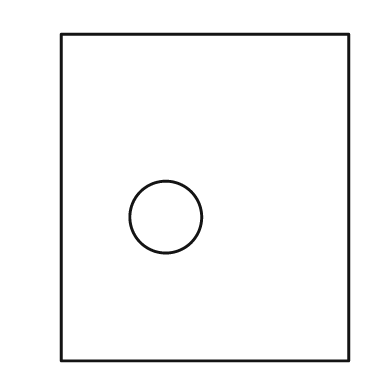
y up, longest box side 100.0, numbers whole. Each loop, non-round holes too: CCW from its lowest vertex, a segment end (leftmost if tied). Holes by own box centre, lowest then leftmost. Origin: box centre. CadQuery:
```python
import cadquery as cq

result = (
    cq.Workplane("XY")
    .moveTo(-44.0, -50.0)
    .lineTo(44.0, -50.0)
    .lineTo(44.0, 50.0)
    .lineTo(-44.0, 50.0)
    .close()
    .moveTo(-12.0, -6.0)
    .circle(11.0)
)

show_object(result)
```